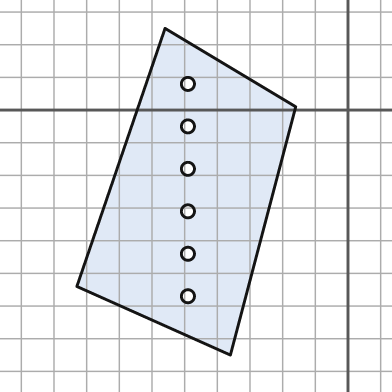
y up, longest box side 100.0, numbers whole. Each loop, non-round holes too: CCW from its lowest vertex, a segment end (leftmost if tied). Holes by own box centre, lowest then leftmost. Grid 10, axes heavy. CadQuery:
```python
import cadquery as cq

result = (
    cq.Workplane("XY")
    .moveTo(-36.0, -75.0)
    .lineTo(-16.0, 1.0)
    .lineTo(-56.0, 25.0)
    .lineTo(-83.0, -54.0)
    .close()
    .moveTo(-49.0, -57.0)
    .circle(2.0)
    .moveTo(-49.0, -44.0)
    .circle(2.0)
    .moveTo(-49.0, -31.0)
    .circle(2.0)
    .moveTo(-49.0, -18.0)
    .circle(2.0)
    .moveTo(-49.0, -5.0)
    .circle(2.0)
    .moveTo(-49.0, 8.0)
    .circle(2.0)
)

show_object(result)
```